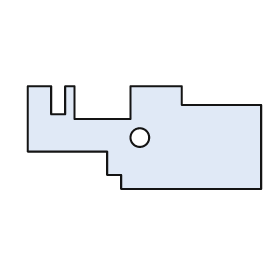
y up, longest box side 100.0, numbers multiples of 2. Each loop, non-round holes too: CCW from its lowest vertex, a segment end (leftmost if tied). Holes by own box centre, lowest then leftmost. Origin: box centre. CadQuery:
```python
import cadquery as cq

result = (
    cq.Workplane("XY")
    .moveTo(-10.0, -22.0)
    .lineTo(50.0, -22.0)
    .lineTo(50.0, 14.0)
    .lineTo(16.0, 14.0)
    .lineTo(16.0, 22.0)
    .lineTo(-6.0, 22.0)
    .lineTo(-6.0, 8.0)
    .lineTo(-30.0, 8.0)
    .lineTo(-30.0, 22.0)
    .lineTo(-34.0, 22.0)
    .lineTo(-34.0, 10.0)
    .lineTo(-40.0, 10.0)
    .lineTo(-40.0, 22.0)
    .lineTo(-50.0, 22.0)
    .lineTo(-50.0, -6.0)
    .lineTo(-16.0, -6.0)
    .lineTo(-16.0, -16.0)
    .lineTo(-10.0, -16.0)
    .close()
    .moveTo(-2.0, 0.0)
    .circle(4.0)
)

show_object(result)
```